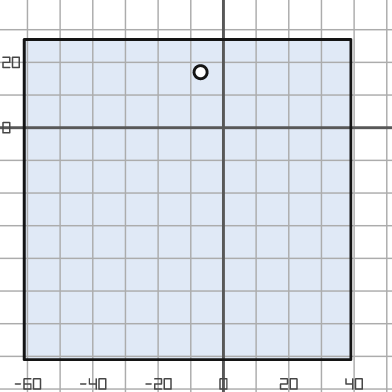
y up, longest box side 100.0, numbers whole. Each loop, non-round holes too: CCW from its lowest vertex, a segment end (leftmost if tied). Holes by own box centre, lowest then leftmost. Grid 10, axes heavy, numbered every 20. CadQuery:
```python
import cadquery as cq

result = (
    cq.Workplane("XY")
    .moveTo(-61.0, -71.0)
    .lineTo(39.0, -71.0)
    .lineTo(39.0, 27.0)
    .lineTo(-61.0, 27.0)
    .close()
    .moveTo(-7.0, 17.0)
    .circle(2.0)
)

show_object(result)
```